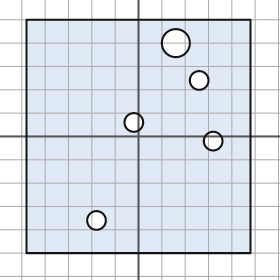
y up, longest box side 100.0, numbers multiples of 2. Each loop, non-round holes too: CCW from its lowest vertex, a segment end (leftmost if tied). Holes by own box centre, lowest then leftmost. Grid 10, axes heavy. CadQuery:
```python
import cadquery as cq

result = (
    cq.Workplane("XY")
    .moveTo(-48.0, -50.0)
    .lineTo(48.0, -50.0)
    .lineTo(48.0, 50.0)
    .lineTo(-48.0, 50.0)
    .close()
    .moveTo(-18.0, -36.0)
    .circle(4.0)
    .moveTo(32.0, -2.0)
    .circle(4.0)
    .moveTo(-2.0, 6.0)
    .circle(4.0)
    .moveTo(26.0, 24.0)
    .circle(4.0)
    .moveTo(16.0, 40.0)
    .circle(6.0)
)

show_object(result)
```